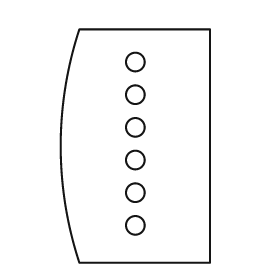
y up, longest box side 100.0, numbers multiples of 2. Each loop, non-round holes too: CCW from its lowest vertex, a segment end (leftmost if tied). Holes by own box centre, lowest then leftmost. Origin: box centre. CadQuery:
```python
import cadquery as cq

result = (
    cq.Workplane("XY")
    .moveTo(-24.0, -50.0)
    .lineTo(32.0, -50.0)
    .lineTo(32.0, 50.0)
    .lineTo(-24.0, 50.0)
    .threePointArc((-32.0, 0.0), (-24.0, -50.0))
    .close()
    .moveTo(0.0, -34.0)
    .circle(4.0)
    .moveTo(0.0, -20.0)
    .circle(4.0)
    .moveTo(0.0, -6.0)
    .circle(4.0)
    .moveTo(0.0, 8.0)
    .circle(4.0)
    .moveTo(0.0, 22.0)
    .circle(4.0)
    .moveTo(0.0, 36.0)
    .circle(4.0)
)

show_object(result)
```